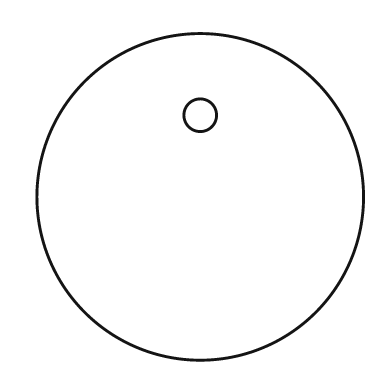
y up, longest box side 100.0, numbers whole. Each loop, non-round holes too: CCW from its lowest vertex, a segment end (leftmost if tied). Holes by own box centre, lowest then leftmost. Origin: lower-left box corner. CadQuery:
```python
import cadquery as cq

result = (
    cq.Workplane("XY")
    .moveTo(50.0, 50.0)
    .circle(50.0)
    .moveTo(50.0, 75.0)
    .circle(5.0)
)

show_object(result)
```